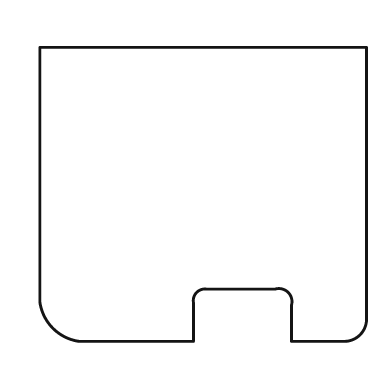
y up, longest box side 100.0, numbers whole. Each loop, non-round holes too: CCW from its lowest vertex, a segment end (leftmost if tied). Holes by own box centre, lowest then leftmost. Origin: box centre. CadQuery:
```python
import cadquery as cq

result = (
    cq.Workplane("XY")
    .moveTo(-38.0, -45.0)
    .lineTo(-3.0, -45.0)
    .lineTo(-3.0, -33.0)
    .threePointArc((-2.0, -30.0), (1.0, -29.0))
    .lineTo(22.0, -29.0)
    .threePointArc((26.0, -30.0), (27.0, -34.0))
    .lineTo(27.0, -45.0)
    .lineTo(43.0, -45.0)
    .threePointArc((48.0, -43.0), (50.0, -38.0))
    .lineTo(50.0, 45.0)
    .lineTo(-50.0, 45.0)
    .lineTo(-50.0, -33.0)
    .threePointArc((-46.0, -41.0), (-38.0, -45.0))
    .close()
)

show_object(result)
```